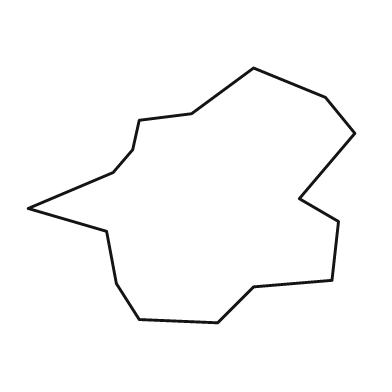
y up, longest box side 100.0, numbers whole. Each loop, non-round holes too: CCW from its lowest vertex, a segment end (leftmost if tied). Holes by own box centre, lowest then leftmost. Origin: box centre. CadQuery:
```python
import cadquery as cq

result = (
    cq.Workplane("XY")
    .moveTo(8.0, -39.0)
    .lineTo(19.0, -28.0)
    .lineTo(43.0, -26.0)
    .lineTo(45.0, -8.0)
    .lineTo(33.0, -1.0)
    .lineTo(50.0, 19.0)
    .lineTo(41.0, 30.0)
    .lineTo(19.0, 39.0)
    .lineTo(0.0, 25.0)
    .lineTo(-16.0, 23.0)
    .lineTo(-18.0, 14.0)
    .lineTo(-24.0, 7.0)
    .lineTo(-50.0, -4.0)
    .lineTo(-26.0, -11.0)
    .lineTo(-23.0, -27.0)
    .lineTo(-16.0, -38.0)
    .close()
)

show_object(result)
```